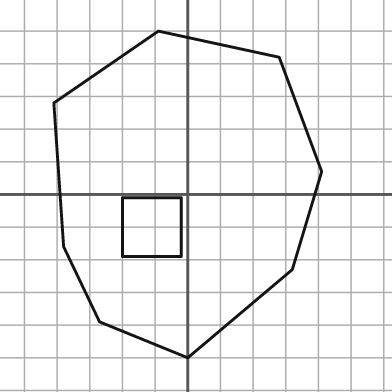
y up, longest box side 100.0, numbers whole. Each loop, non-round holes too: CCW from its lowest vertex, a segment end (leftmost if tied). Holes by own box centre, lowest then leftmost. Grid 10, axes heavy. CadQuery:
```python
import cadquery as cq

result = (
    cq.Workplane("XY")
    .moveTo(0.0, -50.0)
    .lineTo(32.0, -23.0)
    .lineTo(41.0, 7.0)
    .lineTo(28.0, 42.0)
    .lineTo(-9.0, 50.0)
    .lineTo(-41.0, 28.0)
    .lineTo(-38.0, -16.0)
    .lineTo(-27.0, -39.0)
    .close()
    .moveTo(-20.0, -19.0)
    .lineTo(-2.0, -19.0)
    .lineTo(-2.0, -1.0)
    .lineTo(-20.0, -1.0)
    .close()
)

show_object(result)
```